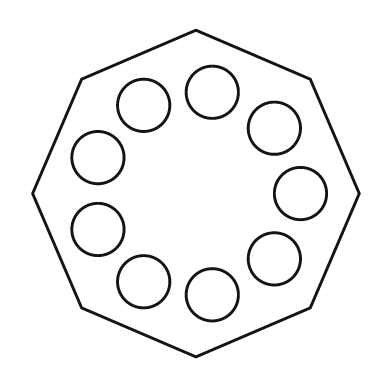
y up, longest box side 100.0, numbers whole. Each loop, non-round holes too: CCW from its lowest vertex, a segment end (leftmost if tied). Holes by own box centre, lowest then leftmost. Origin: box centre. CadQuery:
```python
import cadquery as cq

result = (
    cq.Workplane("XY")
    .moveTo(0.0, -50.0)
    .lineTo(35.0, -35.0)
    .lineTo(50.0, 0.0)
    .lineTo(35.0, 35.0)
    .lineTo(0.0, 50.0)
    .lineTo(-35.0, 35.0)
    .lineTo(-50.0, 0.0)
    .lineTo(-35.0, -35.0)
    .close()
    .moveTo(5.0, -31.0)
    .circle(8.0)
    .moveTo(-16.0, -27.0)
    .circle(8.0)
    .moveTo(24.0, -20.0)
    .circle(8.0)
    .moveTo(-30.0, -11.0)
    .circle(8.0)
    .moveTo(32.0, 0.0)
    .circle(8.0)
    .moveTo(-30.0, 11.0)
    .circle(8.0)
    .moveTo(24.0, 20.0)
    .circle(8.0)
    .moveTo(-16.0, 27.0)
    .circle(8.0)
    .moveTo(5.0, 31.0)
    .circle(8.0)
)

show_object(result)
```